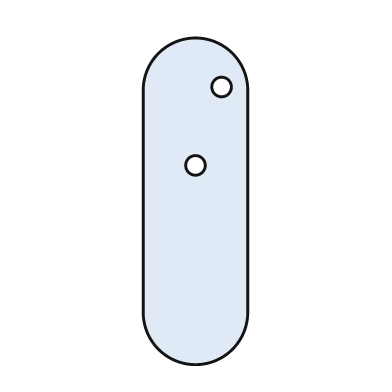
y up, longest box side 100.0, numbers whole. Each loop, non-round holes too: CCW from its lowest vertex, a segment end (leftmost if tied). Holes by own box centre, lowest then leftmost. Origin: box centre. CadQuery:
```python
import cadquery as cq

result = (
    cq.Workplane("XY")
    .moveTo(-16.0, -34.0)
    .threePointArc((0.0, -50.0), (16.0, -34.0))
    .lineTo(16.0, 34.0)
    .threePointArc((0.0, 50.0), (-16.0, 34.0))
    .close()
    .moveTo(0.0, 11.0)
    .circle(3.0)
    .moveTo(8.0, 35.0)
    .circle(3.0)
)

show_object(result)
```